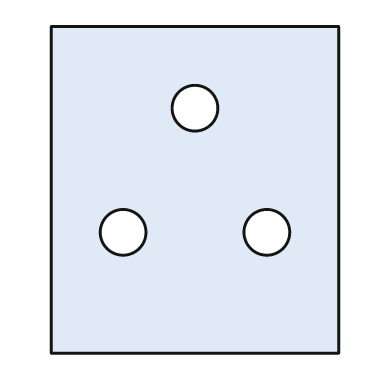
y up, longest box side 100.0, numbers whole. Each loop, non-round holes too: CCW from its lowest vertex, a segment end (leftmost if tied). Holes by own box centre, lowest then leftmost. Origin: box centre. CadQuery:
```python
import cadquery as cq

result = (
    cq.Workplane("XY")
    .moveTo(-44.0, -50.0)
    .lineTo(44.0, -50.0)
    .lineTo(44.0, 50.0)
    .lineTo(-44.0, 50.0)
    .close()
    .moveTo(-22.0, -13.0)
    .circle(7.0)
    .moveTo(22.0, -13.0)
    .circle(7.0)
    .moveTo(0.0, 25.0)
    .circle(7.0)
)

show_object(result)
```